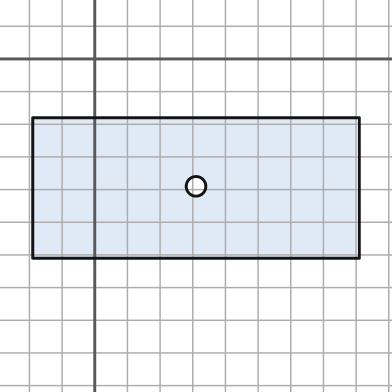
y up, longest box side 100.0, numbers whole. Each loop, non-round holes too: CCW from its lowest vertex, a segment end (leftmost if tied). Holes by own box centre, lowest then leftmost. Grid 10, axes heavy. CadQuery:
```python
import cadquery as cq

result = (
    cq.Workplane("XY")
    .moveTo(-19.0, -61.0)
    .lineTo(81.0, -61.0)
    .lineTo(81.0, -18.0)
    .lineTo(-19.0, -18.0)
    .close()
    .moveTo(31.0, -39.0)
    .circle(3.0)
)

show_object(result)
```